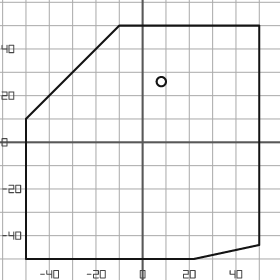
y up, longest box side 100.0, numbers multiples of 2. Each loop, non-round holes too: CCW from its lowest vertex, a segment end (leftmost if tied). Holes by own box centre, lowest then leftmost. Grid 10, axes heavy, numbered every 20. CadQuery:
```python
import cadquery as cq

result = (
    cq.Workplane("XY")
    .moveTo(-50.0, -50.0)
    .lineTo(22.0, -50.0)
    .lineTo(50.0, -44.0)
    .lineTo(50.0, 50.0)
    .lineTo(-10.0, 50.0)
    .lineTo(-50.0, 10.0)
    .close()
    .moveTo(8.0, 26.0)
    .circle(2.0)
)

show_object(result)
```